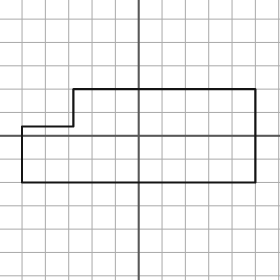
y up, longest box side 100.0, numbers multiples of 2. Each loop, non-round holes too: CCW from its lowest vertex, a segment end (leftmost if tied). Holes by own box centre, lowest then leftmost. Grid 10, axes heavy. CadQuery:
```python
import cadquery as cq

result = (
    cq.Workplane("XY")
    .moveTo(-50.0, -20.0)
    .lineTo(50.0, -20.0)
    .lineTo(50.0, 20.0)
    .lineTo(-28.0, 20.0)
    .lineTo(-28.0, 4.0)
    .lineTo(-50.0, 4.0)
    .close()
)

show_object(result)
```